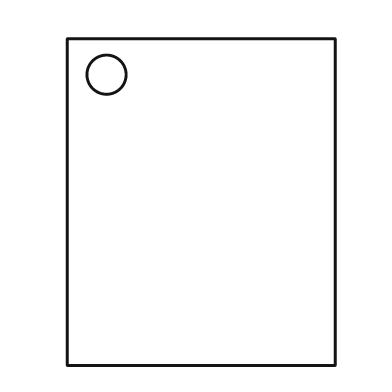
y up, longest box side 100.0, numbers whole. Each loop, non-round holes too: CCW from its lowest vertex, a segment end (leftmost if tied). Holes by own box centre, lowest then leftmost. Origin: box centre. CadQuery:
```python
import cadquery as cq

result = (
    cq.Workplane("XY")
    .moveTo(-41.0, -50.0)
    .lineTo(41.0, -50.0)
    .lineTo(41.0, 50.0)
    .lineTo(-41.0, 50.0)
    .close()
    .moveTo(-29.0, 39.0)
    .circle(6.0)
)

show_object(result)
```